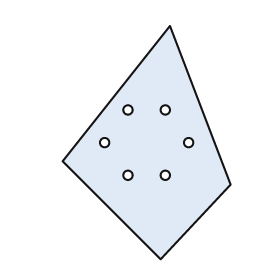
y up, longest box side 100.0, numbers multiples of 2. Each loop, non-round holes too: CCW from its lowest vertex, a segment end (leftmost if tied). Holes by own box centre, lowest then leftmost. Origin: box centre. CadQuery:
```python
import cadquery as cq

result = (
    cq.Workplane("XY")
    .moveTo(6.0, -50.0)
    .lineTo(36.0, -18.0)
    .lineTo(10.0, 50.0)
    .lineTo(-36.0, -8.0)
    .close()
    .moveTo(-8.0, -14.0)
    .circle(2.0)
    .moveTo(8.0, -14.0)
    .circle(2.0)
    .moveTo(-18.0, 0.0)
    .circle(2.0)
    .moveTo(18.0, 0.0)
    .circle(2.0)
    .moveTo(-8.0, 14.0)
    .circle(2.0)
    .moveTo(8.0, 14.0)
    .circle(2.0)
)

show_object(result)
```